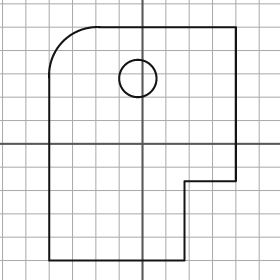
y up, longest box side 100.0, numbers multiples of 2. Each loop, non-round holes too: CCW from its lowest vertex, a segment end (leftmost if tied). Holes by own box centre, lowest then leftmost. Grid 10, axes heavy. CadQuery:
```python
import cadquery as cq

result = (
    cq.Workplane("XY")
    .moveTo(-40.0, -50.0)
    .lineTo(18.0, -50.0)
    .lineTo(18.0, -16.0)
    .lineTo(40.0, -16.0)
    .lineTo(40.0, 50.0)
    .lineTo(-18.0, 50.0)
    .threePointArc((-34.0, 44.0), (-40.0, 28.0))
    .close()
    .moveTo(-2.0, 28.0)
    .circle(8.0)
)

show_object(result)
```